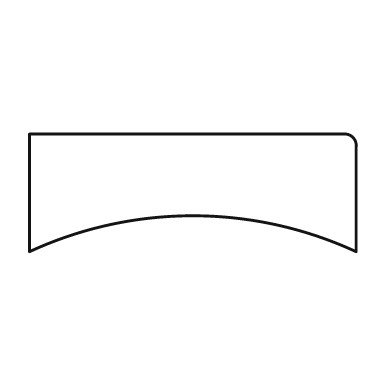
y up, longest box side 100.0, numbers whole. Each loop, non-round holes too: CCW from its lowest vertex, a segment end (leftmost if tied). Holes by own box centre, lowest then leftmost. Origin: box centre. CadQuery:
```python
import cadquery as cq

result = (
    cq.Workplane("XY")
    .moveTo(-50.0, -18.0)
    .threePointArc((0.0, -7.0), (50.0, -18.0))
    .lineTo(50.0, 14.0)
    .threePointArc((49.0, 17.0), (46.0, 18.0))
    .lineTo(-50.0, 18.0)
    .close()
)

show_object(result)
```